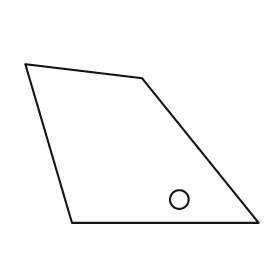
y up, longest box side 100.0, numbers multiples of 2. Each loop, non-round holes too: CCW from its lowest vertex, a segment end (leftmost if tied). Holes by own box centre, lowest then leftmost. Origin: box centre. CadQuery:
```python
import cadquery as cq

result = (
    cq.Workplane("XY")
    .moveTo(-30.0, -34.0)
    .lineTo(50.0, -34.0)
    .lineTo(0.0, 28.0)
    .lineTo(-50.0, 34.0)
    .close()
    .moveTo(16.0, -24.0)
    .circle(4.0)
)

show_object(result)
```